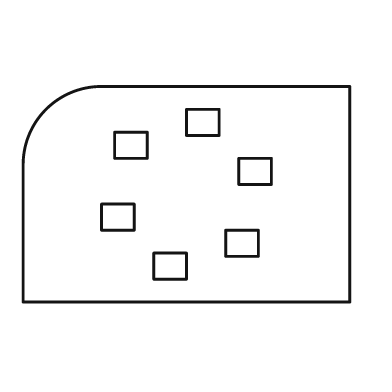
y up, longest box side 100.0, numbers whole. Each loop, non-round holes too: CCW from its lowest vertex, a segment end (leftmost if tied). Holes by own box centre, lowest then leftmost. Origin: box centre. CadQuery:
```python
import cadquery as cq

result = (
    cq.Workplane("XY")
    .moveTo(-50.0, -33.0)
    .lineTo(50.0, -33.0)
    .lineTo(50.0, 33.0)
    .lineTo(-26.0, 33.0)
    .threePointArc((-43.0, 26.0), (-50.0, 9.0))
    .close()
    .moveTo(-10.0, -26.0)
    .lineTo(0.0, -26.0)
    .lineTo(0.0, -18.0)
    .lineTo(-10.0, -18.0)
    .close()
    .moveTo(12.0, -19.0)
    .lineTo(22.0, -19.0)
    .lineTo(22.0, -11.0)
    .lineTo(12.0, -11.0)
    .close()
    .moveTo(-26.0, -11.0)
    .lineTo(-16.0, -11.0)
    .lineTo(-16.0, -3.0)
    .lineTo(-26.0, -3.0)
    .close()
    .moveTo(16.0, 3.0)
    .lineTo(26.0, 3.0)
    .lineTo(26.0, 11.0)
    .lineTo(16.0, 11.0)
    .close()
    .moveTo(-22.0, 11.0)
    .lineTo(-12.0, 11.0)
    .lineTo(-12.0, 19.0)
    .lineTo(-22.0, 19.0)
    .close()
    .moveTo(0.0, 18.0)
    .lineTo(10.0, 18.0)
    .lineTo(10.0, 26.0)
    .lineTo(0.0, 26.0)
    .close()
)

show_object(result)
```